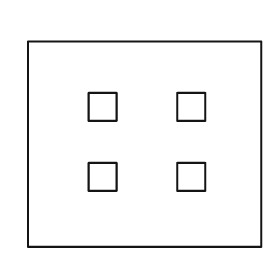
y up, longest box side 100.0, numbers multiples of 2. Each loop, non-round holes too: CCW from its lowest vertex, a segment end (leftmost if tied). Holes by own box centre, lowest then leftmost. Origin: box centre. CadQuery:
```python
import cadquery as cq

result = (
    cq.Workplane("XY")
    .moveTo(-50.0, -44.0)
    .lineTo(50.0, -44.0)
    .lineTo(50.0, 44.0)
    .lineTo(-50.0, 44.0)
    .close()
    .moveTo(-24.0, -20.0)
    .lineTo(-12.0, -20.0)
    .lineTo(-12.0, -8.0)
    .lineTo(-24.0, -8.0)
    .close()
    .moveTo(14.0, -20.0)
    .lineTo(26.0, -20.0)
    .lineTo(26.0, -8.0)
    .lineTo(14.0, -8.0)
    .close()
    .moveTo(-24.0, 10.0)
    .lineTo(-12.0, 10.0)
    .lineTo(-12.0, 22.0)
    .lineTo(-24.0, 22.0)
    .close()
    .moveTo(14.0, 10.0)
    .lineTo(26.0, 10.0)
    .lineTo(26.0, 22.0)
    .lineTo(14.0, 22.0)
    .close()
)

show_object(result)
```